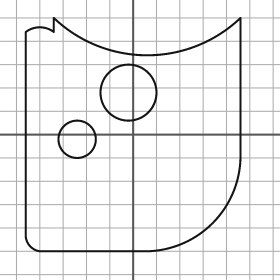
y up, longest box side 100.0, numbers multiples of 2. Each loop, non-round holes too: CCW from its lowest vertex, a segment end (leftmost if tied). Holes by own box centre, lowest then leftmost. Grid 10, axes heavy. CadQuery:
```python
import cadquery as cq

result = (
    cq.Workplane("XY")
    .moveTo(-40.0, -50.0)
    .lineTo(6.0, -50.0)
    .threePointArc((34.0, -38.0), (46.0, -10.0))
    .lineTo(46.0, 50.0)
    .threePointArc((6.0, 34.0), (-34.0, 50.0))
    .lineTo(-34.0, 44.0)
    .threePointArc((-40.0, 46.0), (-46.0, 44.0))
    .lineTo(-46.0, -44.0)
    .threePointArc((-44.0, -48.0), (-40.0, -50.0))
    .close()
    .moveTo(-24.0, -2.0)
    .circle(8.0)
    .moveTo(-2.0, 18.0)
    .circle(12.0)
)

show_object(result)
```